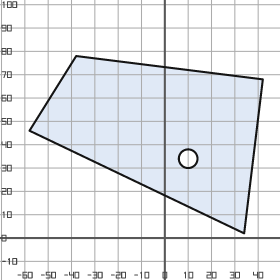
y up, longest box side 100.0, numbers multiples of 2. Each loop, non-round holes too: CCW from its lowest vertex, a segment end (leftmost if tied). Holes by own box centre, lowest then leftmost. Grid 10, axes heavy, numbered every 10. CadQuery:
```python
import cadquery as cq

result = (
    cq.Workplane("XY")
    .moveTo(34.0, 2.0)
    .lineTo(42.0, 68.0)
    .lineTo(-38.0, 78.0)
    .lineTo(-58.0, 46.0)
    .close()
    .moveTo(10.0, 34.0)
    .circle(4.0)
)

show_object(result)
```